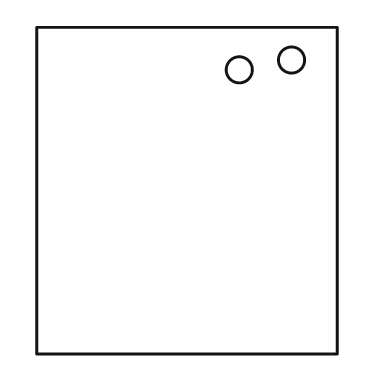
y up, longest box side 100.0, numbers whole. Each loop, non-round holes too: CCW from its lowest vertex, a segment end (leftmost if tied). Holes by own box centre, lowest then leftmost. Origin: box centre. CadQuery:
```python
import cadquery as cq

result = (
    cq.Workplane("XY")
    .moveTo(-46.0, -50.0)
    .lineTo(46.0, -50.0)
    .lineTo(46.0, 50.0)
    .lineTo(-46.0, 50.0)
    .close()
    .moveTo(16.0, 37.0)
    .circle(4.0)
    .moveTo(32.0, 40.0)
    .circle(4.0)
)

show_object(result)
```